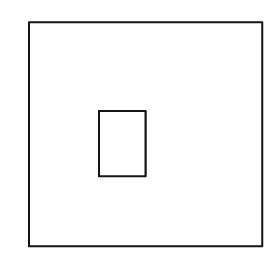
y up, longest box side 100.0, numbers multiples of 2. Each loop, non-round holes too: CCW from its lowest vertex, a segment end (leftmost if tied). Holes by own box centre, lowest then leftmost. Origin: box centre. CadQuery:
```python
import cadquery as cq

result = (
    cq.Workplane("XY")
    .moveTo(-50.0, -48.0)
    .lineTo(50.0, -48.0)
    .lineTo(50.0, 48.0)
    .lineTo(-50.0, 48.0)
    .close()
    .moveTo(-20.0, -18.0)
    .lineTo(0.0, -18.0)
    .lineTo(0.0, 10.0)
    .lineTo(-20.0, 10.0)
    .close()
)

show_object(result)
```